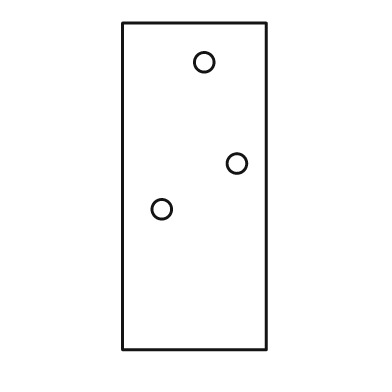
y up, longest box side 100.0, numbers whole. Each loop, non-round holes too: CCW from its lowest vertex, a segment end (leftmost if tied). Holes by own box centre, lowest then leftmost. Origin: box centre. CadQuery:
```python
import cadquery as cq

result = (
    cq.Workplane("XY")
    .moveTo(-22.0, -50.0)
    .lineTo(22.0, -50.0)
    .lineTo(22.0, 50.0)
    .lineTo(-22.0, 50.0)
    .close()
    .moveTo(-10.0, -7.0)
    .circle(3.0)
    .moveTo(13.0, 7.0)
    .circle(3.0)
    .moveTo(3.0, 38.0)
    .circle(3.0)
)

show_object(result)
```